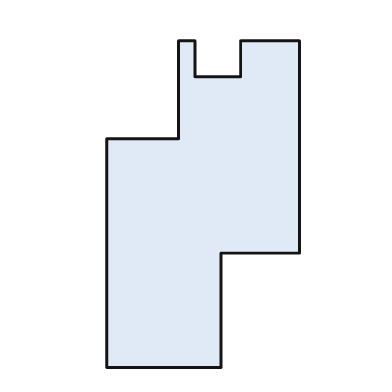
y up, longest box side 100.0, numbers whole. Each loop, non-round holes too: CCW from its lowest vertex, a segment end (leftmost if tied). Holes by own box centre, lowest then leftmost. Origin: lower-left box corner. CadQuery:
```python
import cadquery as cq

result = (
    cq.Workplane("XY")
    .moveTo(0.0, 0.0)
    .lineTo(35.0, 0.0)
    .lineTo(35.0, 35.0)
    .lineTo(59.0, 35.0)
    .lineTo(59.0, 100.0)
    .lineTo(41.0, 100.0)
    .lineTo(41.0, 89.0)
    .lineTo(27.0, 89.0)
    .lineTo(27.0, 100.0)
    .lineTo(22.0, 100.0)
    .lineTo(22.0, 70.0)
    .lineTo(0.0, 70.0)
    .close()
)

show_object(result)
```